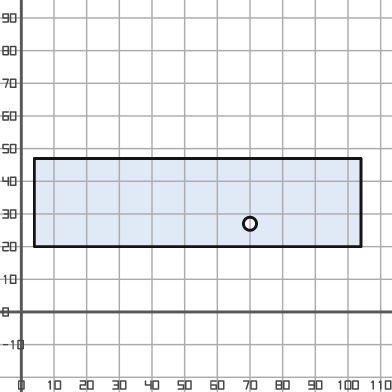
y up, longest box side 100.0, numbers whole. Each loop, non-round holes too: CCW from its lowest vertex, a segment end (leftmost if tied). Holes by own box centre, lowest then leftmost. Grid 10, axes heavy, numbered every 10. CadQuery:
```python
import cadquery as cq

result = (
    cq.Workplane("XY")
    .moveTo(4.0, 20.0)
    .lineTo(104.0, 20.0)
    .lineTo(104.0, 47.0)
    .lineTo(4.0, 47.0)
    .close()
    .moveTo(70.0, 27.0)
    .circle(2.0)
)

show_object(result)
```